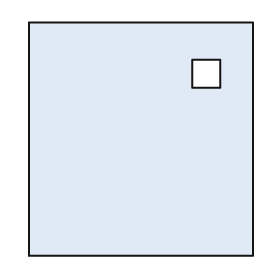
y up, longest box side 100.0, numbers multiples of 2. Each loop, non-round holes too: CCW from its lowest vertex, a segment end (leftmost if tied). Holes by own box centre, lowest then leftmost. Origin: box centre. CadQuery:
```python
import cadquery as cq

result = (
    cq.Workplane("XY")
    .moveTo(-48.0, -50.0)
    .lineTo(48.0, -50.0)
    .lineTo(48.0, 50.0)
    .lineTo(-48.0, 50.0)
    .close()
    .moveTo(22.0, 22.0)
    .lineTo(34.0, 22.0)
    .lineTo(34.0, 34.0)
    .lineTo(22.0, 34.0)
    .close()
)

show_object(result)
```